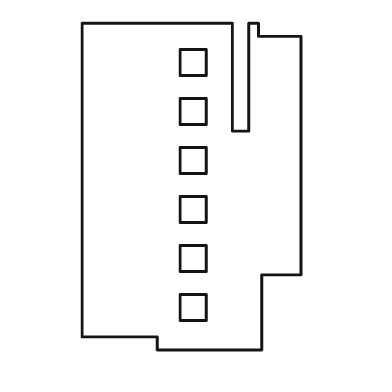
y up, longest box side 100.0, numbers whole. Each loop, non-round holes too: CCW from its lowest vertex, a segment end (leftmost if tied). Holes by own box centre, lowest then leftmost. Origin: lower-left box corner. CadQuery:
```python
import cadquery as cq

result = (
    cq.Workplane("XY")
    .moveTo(23.0, 0.0)
    .lineTo(55.0, 0.0)
    .lineTo(55.0, 23.0)
    .lineTo(67.0, 23.0)
    .lineTo(67.0, 96.0)
    .lineTo(54.0, 96.0)
    .lineTo(54.0, 100.0)
    .lineTo(51.0, 100.0)
    .lineTo(51.0, 67.0)
    .lineTo(46.0, 67.0)
    .lineTo(46.0, 100.0)
    .lineTo(0.0, 100.0)
    .lineTo(0.0, 4.0)
    .lineTo(23.0, 4.0)
    .close()
    .moveTo(30.0, 9.0)
    .lineTo(38.0, 9.0)
    .lineTo(38.0, 17.0)
    .lineTo(30.0, 17.0)
    .close()
    .moveTo(30.0, 24.0)
    .lineTo(38.0, 24.0)
    .lineTo(38.0, 32.0)
    .lineTo(30.0, 32.0)
    .close()
    .moveTo(30.0, 39.0)
    .lineTo(38.0, 39.0)
    .lineTo(38.0, 47.0)
    .lineTo(30.0, 47.0)
    .close()
    .moveTo(30.0, 54.0)
    .lineTo(38.0, 54.0)
    .lineTo(38.0, 62.0)
    .lineTo(30.0, 62.0)
    .close()
    .moveTo(30.0, 69.0)
    .lineTo(38.0, 69.0)
    .lineTo(38.0, 77.0)
    .lineTo(30.0, 77.0)
    .close()
    .moveTo(30.0, 84.0)
    .lineTo(38.0, 84.0)
    .lineTo(38.0, 92.0)
    .lineTo(30.0, 92.0)
    .close()
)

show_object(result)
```